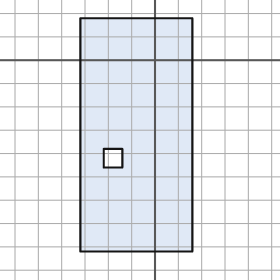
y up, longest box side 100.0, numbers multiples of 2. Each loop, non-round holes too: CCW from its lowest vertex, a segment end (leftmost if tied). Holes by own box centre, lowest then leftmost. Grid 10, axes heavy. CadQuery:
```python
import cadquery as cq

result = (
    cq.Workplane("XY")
    .moveTo(-32.0, -82.0)
    .lineTo(16.0, -82.0)
    .lineTo(16.0, 18.0)
    .lineTo(-32.0, 18.0)
    .close()
    .moveTo(-22.0, -46.0)
    .lineTo(-14.0, -46.0)
    .lineTo(-14.0, -38.0)
    .lineTo(-22.0, -38.0)
    .close()
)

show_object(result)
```